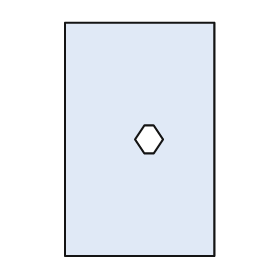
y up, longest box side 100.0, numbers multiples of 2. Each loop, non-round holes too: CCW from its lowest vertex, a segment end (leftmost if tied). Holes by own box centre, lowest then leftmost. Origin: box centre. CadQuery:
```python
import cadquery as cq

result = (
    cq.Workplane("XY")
    .moveTo(-32.0, -50.0)
    .lineTo(32.0, -50.0)
    .lineTo(32.0, 50.0)
    .lineTo(-32.0, 50.0)
    .close()
    .moveTo(2.0, -6.0)
    .lineTo(6.0, -6.0)
    .lineTo(10.0, 0.0)
    .lineTo(6.0, 6.0)
    .lineTo(2.0, 6.0)
    .lineTo(-2.0, 0.0)
    .close()
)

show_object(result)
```